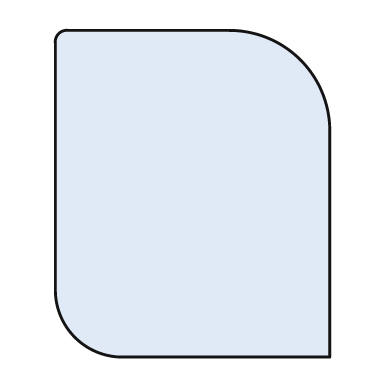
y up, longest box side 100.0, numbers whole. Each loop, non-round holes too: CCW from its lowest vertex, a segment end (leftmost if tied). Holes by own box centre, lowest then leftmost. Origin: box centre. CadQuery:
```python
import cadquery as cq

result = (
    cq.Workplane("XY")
    .moveTo(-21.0, -50.0)
    .lineTo(42.0, -50.0)
    .lineTo(42.0, 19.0)
    .threePointArc((33.0, 41.0), (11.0, 50.0))
    .lineTo(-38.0, 50.0)
    .threePointArc((-41.0, 49.0), (-42.0, 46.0))
    .lineTo(-42.0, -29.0)
    .threePointArc((-36.0, -44.0), (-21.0, -50.0))
    .close()
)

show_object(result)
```